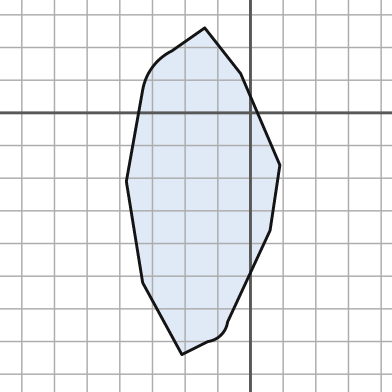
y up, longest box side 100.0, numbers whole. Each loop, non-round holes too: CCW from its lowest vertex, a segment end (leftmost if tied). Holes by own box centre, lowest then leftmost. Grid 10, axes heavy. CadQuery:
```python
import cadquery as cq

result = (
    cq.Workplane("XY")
    .moveTo(-21.0, -74.0)
    .lineTo(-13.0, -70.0)
    .threePointArc((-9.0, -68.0), (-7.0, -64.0))
    .lineTo(6.0, -36.0)
    .lineTo(9.0, -16.0)
    .lineTo(-3.0, 12.0)
    .lineTo(-14.0, 26.0)
    .lineTo(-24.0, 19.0)
    .threePointArc((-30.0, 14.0), (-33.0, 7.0))
    .lineTo(-38.0, -21.0)
    .lineTo(-33.0, -52.0)
    .close()
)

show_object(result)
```